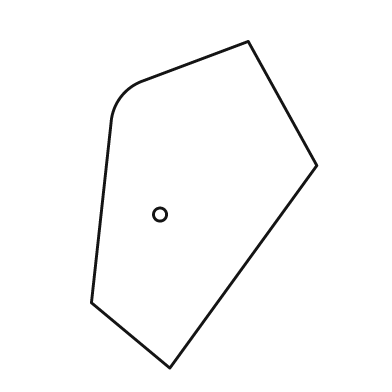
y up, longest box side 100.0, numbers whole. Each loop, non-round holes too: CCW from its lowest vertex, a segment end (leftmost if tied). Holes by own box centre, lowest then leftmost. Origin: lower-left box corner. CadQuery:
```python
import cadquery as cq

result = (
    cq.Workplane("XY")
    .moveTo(24.0, 0.0)
    .lineTo(69.0, 62.0)
    .lineTo(48.0, 100.0)
    .lineTo(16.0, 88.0)
    .threePointArc((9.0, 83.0), (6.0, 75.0))
    .lineTo(0.0, 20.0)
    .close()
    .moveTo(21.0, 47.0)
    .circle(2.0)
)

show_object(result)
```